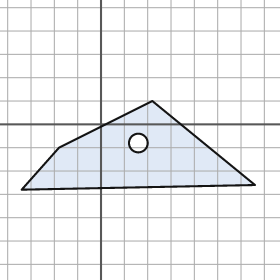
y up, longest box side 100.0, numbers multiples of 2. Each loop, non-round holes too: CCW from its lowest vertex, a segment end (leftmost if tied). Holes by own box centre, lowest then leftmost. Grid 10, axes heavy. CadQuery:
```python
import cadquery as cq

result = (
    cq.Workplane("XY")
    .moveTo(-34.0, -28.0)
    .lineTo(66.0, -26.0)
    .lineTo(22.0, 10.0)
    .lineTo(-18.0, -10.0)
    .close()
    .moveTo(16.0, -8.0)
    .circle(4.0)
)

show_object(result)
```